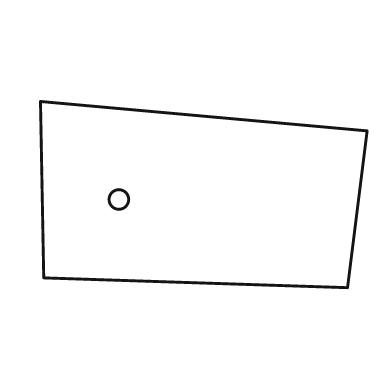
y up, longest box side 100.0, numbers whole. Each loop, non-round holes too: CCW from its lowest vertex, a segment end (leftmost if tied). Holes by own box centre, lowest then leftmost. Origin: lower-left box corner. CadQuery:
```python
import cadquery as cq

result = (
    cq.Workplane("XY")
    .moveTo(94.0, 0.0)
    .lineTo(100.0, 48.0)
    .lineTo(0.0, 57.0)
    .lineTo(1.0, 3.0)
    .close()
    .moveTo(24.0, 27.0)
    .circle(3.0)
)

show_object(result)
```